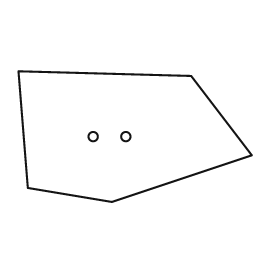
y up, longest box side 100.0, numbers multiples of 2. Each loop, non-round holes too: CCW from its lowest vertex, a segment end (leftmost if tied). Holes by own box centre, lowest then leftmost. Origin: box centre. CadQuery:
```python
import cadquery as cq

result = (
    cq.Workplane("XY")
    .moveTo(-10.0, -28.0)
    .lineTo(50.0, -8.0)
    .lineTo(24.0, 26.0)
    .lineTo(-50.0, 28.0)
    .lineTo(-46.0, -22.0)
    .close()
    .moveTo(-18.0, 0.0)
    .circle(2.0)
    .moveTo(-4.0, 0.0)
    .circle(2.0)
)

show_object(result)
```